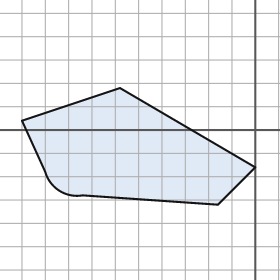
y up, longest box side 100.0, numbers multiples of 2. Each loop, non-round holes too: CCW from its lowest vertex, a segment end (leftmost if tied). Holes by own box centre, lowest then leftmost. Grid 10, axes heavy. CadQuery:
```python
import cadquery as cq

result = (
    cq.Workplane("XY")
    .moveTo(-16.0, -32.0)
    .lineTo(0.0, -16.0)
    .lineTo(-58.0, 18.0)
    .lineTo(-100.0, 4.0)
    .lineTo(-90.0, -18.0)
    .threePointArc((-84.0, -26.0), (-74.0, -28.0))
    .close()
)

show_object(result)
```